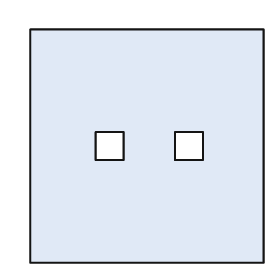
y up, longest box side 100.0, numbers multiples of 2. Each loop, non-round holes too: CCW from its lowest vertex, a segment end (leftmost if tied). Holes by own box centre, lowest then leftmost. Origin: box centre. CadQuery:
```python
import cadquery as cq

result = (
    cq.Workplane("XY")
    .moveTo(-50.0, -50.0)
    .lineTo(50.0, -50.0)
    .lineTo(50.0, 50.0)
    .lineTo(-50.0, 50.0)
    .close()
    .moveTo(-22.0, -6.0)
    .lineTo(-10.0, -6.0)
    .lineTo(-10.0, 6.0)
    .lineTo(-22.0, 6.0)
    .close()
    .moveTo(12.0, -6.0)
    .lineTo(24.0, -6.0)
    .lineTo(24.0, 6.0)
    .lineTo(12.0, 6.0)
    .close()
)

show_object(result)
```